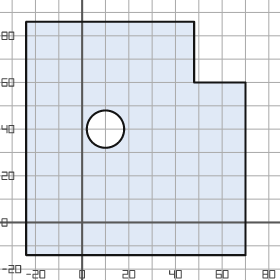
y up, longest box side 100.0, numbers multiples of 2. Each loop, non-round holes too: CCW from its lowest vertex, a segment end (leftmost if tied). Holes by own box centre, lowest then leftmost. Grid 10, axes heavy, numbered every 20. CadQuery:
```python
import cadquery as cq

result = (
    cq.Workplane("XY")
    .moveTo(-24.0, -14.0)
    .lineTo(70.0, -14.0)
    .lineTo(70.0, 60.0)
    .lineTo(48.0, 60.0)
    .lineTo(48.0, 86.0)
    .lineTo(-24.0, 86.0)
    .close()
    .moveTo(10.0, 40.0)
    .circle(8.0)
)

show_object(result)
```